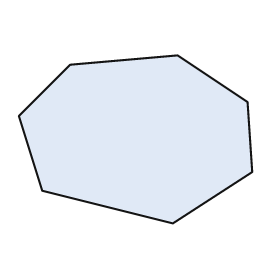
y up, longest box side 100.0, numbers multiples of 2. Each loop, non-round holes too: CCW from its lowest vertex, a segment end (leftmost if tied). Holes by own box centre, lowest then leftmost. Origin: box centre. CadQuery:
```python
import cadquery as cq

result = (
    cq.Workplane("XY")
    .moveTo(16.0, -36.0)
    .lineTo(50.0, -14.0)
    .lineTo(48.0, 16.0)
    .lineTo(18.0, 36.0)
    .lineTo(-28.0, 32.0)
    .lineTo(-50.0, 10.0)
    .lineTo(-40.0, -22.0)
    .close()
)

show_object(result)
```